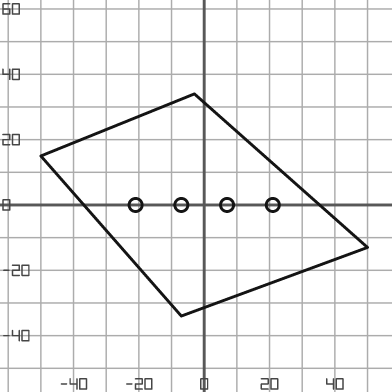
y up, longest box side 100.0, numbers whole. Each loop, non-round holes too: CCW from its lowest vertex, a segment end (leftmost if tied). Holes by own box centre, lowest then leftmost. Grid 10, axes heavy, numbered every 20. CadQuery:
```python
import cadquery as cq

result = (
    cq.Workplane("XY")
    .moveTo(-7.0, -34.0)
    .lineTo(50.0, -13.0)
    .lineTo(-3.0, 34.0)
    .lineTo(-50.0, 15.0)
    .close()
    .moveTo(-21.0, 0.0)
    .circle(2.0)
    .moveTo(-7.0, 0.0)
    .circle(2.0)
    .moveTo(7.0, 0.0)
    .circle(2.0)
    .moveTo(21.0, 0.0)
    .circle(2.0)
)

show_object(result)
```